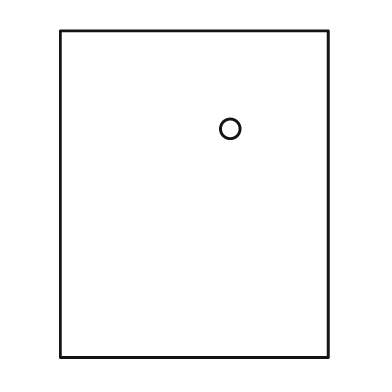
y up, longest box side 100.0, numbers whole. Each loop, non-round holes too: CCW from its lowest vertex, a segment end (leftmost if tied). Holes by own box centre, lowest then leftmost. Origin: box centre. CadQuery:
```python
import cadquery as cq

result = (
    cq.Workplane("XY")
    .moveTo(-41.0, -50.0)
    .lineTo(41.0, -50.0)
    .lineTo(41.0, 50.0)
    .lineTo(-41.0, 50.0)
    .close()
    .moveTo(11.0, 20.0)
    .circle(3.0)
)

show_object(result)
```